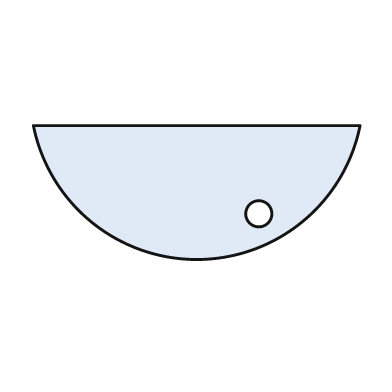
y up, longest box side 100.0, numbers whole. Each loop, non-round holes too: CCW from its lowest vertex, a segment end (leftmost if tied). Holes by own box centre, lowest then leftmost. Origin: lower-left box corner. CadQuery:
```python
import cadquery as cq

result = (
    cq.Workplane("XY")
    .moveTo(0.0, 41.0)
    .threePointArc((50.0, 0.0), (100.0, 41.0))
    .close()
    .moveTo(69.0, 14.0)
    .circle(4.0)
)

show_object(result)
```